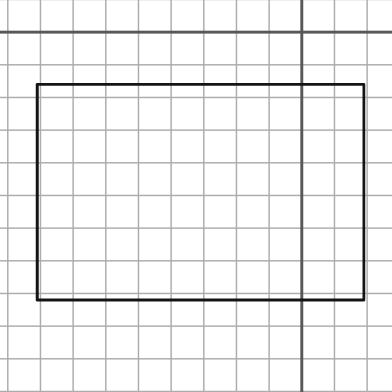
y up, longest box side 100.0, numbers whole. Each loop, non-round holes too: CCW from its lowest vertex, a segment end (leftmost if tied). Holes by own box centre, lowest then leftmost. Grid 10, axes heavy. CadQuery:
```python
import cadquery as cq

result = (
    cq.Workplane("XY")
    .moveTo(-81.0, -82.0)
    .lineTo(19.0, -82.0)
    .lineTo(19.0, -16.0)
    .lineTo(-81.0, -16.0)
    .close()
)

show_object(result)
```